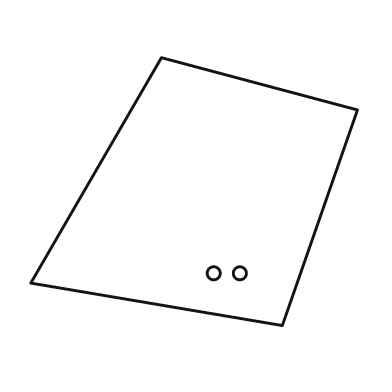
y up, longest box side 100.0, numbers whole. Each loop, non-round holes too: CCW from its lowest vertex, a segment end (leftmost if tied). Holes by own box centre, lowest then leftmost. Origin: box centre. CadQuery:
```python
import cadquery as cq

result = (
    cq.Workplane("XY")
    .moveTo(27.0, -41.0)
    .lineTo(50.0, 25.0)
    .lineTo(-10.0, 41.0)
    .lineTo(-50.0, -28.0)
    .close()
    .moveTo(6.0, -25.0)
    .circle(2.0)
    .moveTo(14.0, -25.0)
    .circle(2.0)
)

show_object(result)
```